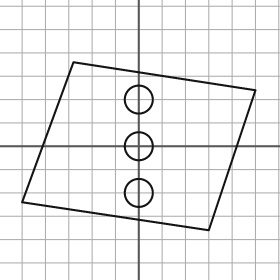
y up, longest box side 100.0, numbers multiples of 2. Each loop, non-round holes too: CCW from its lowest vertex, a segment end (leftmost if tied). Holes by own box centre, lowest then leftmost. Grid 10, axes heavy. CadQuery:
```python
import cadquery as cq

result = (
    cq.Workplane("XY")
    .moveTo(30.0, -36.0)
    .lineTo(50.0, 24.0)
    .lineTo(-28.0, 36.0)
    .lineTo(-50.0, -24.0)
    .close()
    .moveTo(0.0, -20.0)
    .circle(6.0)
    .moveTo(0.0, 0.0)
    .circle(6.0)
    .moveTo(0.0, 20.0)
    .circle(6.0)
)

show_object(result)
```